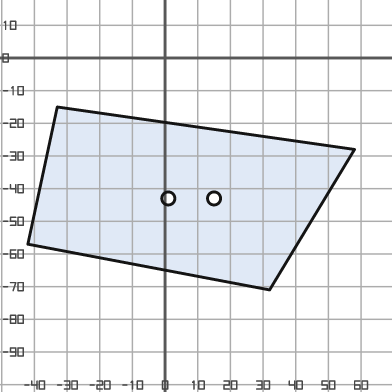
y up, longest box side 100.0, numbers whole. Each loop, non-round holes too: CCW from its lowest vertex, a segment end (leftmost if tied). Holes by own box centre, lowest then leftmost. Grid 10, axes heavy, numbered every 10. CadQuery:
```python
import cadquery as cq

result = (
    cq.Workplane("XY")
    .moveTo(32.0, -71.0)
    .lineTo(58.0, -28.0)
    .lineTo(-33.0, -15.0)
    .lineTo(-42.0, -57.0)
    .close()
    .moveTo(1.0, -43.0)
    .circle(2.0)
    .moveTo(15.0, -43.0)
    .circle(2.0)
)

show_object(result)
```